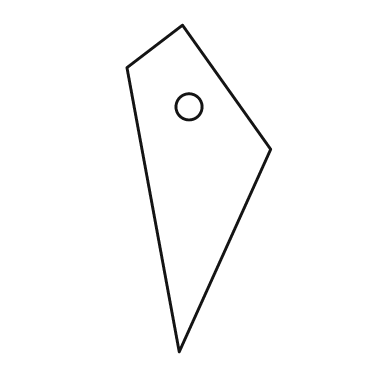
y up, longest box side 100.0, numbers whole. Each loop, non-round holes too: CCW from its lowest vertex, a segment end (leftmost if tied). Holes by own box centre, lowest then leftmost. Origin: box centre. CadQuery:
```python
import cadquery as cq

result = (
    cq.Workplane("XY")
    .moveTo(-6.0, -50.0)
    .lineTo(22.0, 12.0)
    .lineTo(-5.0, 50.0)
    .lineTo(-22.0, 37.0)
    .close()
    .moveTo(-3.0, 25.0)
    .circle(4.0)
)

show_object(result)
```